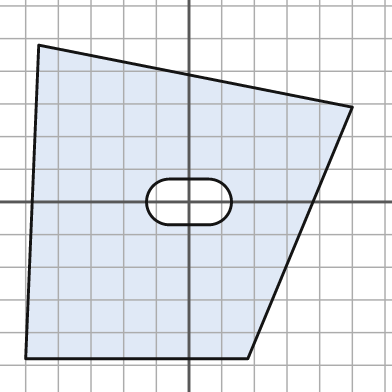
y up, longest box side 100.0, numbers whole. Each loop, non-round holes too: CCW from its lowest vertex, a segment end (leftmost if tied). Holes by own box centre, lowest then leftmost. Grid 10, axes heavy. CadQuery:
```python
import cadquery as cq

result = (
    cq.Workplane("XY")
    .moveTo(-50.0, -48.0)
    .lineTo(18.0, -48.0)
    .lineTo(50.0, 29.0)
    .lineTo(-46.0, 48.0)
    .close()
    .moveTo(-6.0, -7.0)
    .lineTo(6.0, -7.0)
    .threePointArc((13.0, 0.0), (6.0, 7.0))
    .lineTo(-6.0, 7.0)
    .threePointArc((-13.0, 0.0), (-6.0, -7.0))
    .close()
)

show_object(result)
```